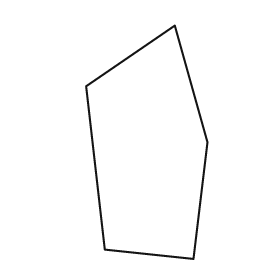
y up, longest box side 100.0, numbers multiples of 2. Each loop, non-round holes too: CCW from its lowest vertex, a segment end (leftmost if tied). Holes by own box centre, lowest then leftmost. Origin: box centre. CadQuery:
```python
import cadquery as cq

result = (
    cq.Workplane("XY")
    .moveTo(20.0, -50.0)
    .lineTo(26.0, 0.0)
    .lineTo(12.0, 50.0)
    .lineTo(-26.0, 24.0)
    .lineTo(-18.0, -46.0)
    .close()
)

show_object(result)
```